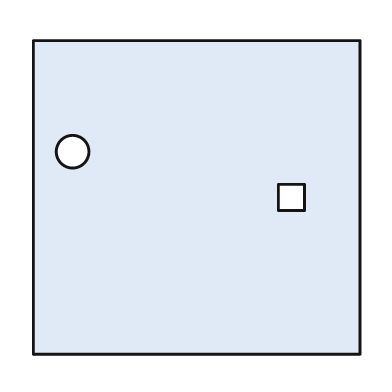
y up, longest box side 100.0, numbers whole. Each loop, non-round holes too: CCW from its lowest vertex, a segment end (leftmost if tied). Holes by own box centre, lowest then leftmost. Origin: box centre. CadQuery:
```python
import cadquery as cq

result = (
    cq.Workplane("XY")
    .moveTo(-50.0, -48.0)
    .lineTo(50.0, -48.0)
    .lineTo(50.0, 48.0)
    .lineTo(-50.0, 48.0)
    .close()
    .moveTo(25.0, -4.0)
    .lineTo(33.0, -4.0)
    .lineTo(33.0, 4.0)
    .lineTo(25.0, 4.0)
    .close()
    .moveTo(-38.0, 14.0)
    .circle(5.0)
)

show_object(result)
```